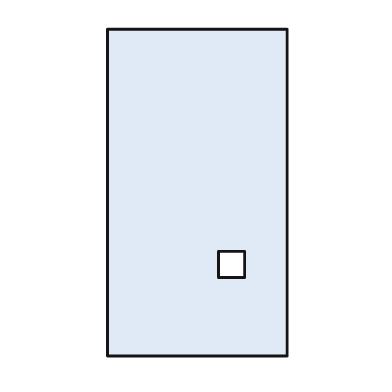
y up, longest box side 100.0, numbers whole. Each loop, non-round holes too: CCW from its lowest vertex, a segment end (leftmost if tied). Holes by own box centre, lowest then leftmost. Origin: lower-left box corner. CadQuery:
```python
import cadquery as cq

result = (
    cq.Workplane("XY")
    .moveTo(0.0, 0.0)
    .lineTo(55.0, 0.0)
    .lineTo(55.0, 100.0)
    .lineTo(0.0, 100.0)
    .close()
    .moveTo(34.0, 24.0)
    .lineTo(42.0, 24.0)
    .lineTo(42.0, 32.0)
    .lineTo(34.0, 32.0)
    .close()
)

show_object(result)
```